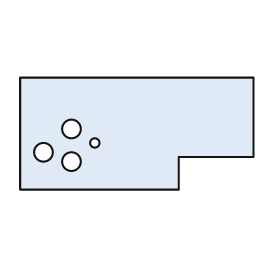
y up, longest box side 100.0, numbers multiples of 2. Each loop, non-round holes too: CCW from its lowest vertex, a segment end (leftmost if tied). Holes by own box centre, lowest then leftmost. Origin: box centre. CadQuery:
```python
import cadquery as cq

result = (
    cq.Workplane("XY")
    .moveTo(-50.0, -24.0)
    .lineTo(18.0, -24.0)
    .lineTo(18.0, -10.0)
    .lineTo(50.0, -10.0)
    .lineTo(50.0, 24.0)
    .lineTo(-50.0, 24.0)
    .close()
    .moveTo(-28.0, -12.0)
    .circle(4.0)
    .moveTo(-40.0, -8.0)
    .circle(4.0)
    .moveTo(-18.0, -4.0)
    .circle(2.0)
    .moveTo(-28.0, 2.0)
    .circle(4.0)
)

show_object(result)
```